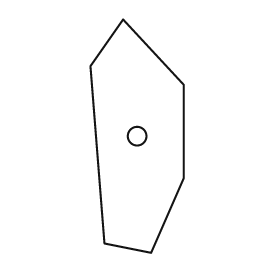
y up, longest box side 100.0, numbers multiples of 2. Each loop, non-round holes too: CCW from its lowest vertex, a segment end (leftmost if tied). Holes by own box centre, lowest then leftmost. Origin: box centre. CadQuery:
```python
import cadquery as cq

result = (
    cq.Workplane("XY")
    .moveTo(6.0, -50.0)
    .lineTo(20.0, -18.0)
    .lineTo(20.0, 22.0)
    .lineTo(-6.0, 50.0)
    .lineTo(-20.0, 30.0)
    .lineTo(-14.0, -46.0)
    .close()
    .moveTo(0.0, 0.0)
    .circle(4.0)
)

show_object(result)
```